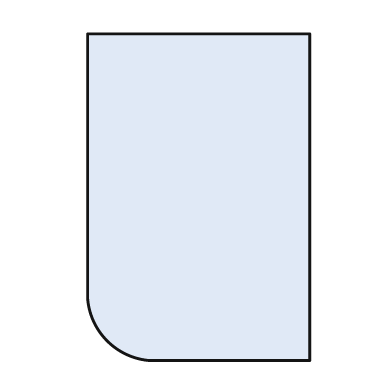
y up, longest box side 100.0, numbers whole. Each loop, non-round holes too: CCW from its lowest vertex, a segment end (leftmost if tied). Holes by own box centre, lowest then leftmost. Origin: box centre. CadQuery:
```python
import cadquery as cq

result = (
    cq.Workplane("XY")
    .moveTo(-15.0, -50.0)
    .lineTo(34.0, -50.0)
    .lineTo(34.0, 50.0)
    .lineTo(-34.0, 50.0)
    .lineTo(-34.0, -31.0)
    .threePointArc((-28.0, -44.0), (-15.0, -50.0))
    .close()
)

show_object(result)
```